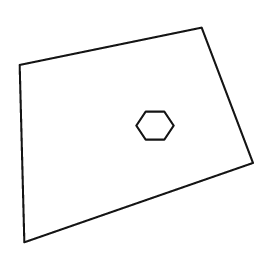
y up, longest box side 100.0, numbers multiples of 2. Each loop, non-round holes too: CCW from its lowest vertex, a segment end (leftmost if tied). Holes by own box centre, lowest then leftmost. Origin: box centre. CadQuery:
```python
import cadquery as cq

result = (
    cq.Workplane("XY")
    .moveTo(-48.0, -46.0)
    .lineTo(50.0, -12.0)
    .lineTo(28.0, 46.0)
    .lineTo(-50.0, 30.0)
    .close()
    .moveTo(4.0, -2.0)
    .lineTo(12.0, -2.0)
    .lineTo(16.0, 4.0)
    .lineTo(12.0, 10.0)
    .lineTo(4.0, 10.0)
    .lineTo(0.0, 4.0)
    .close()
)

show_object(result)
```